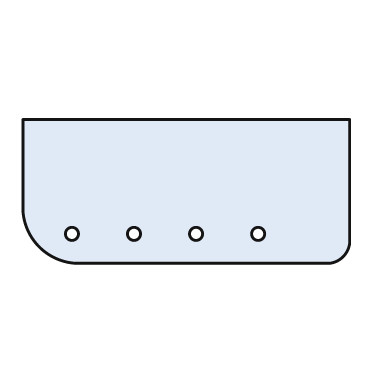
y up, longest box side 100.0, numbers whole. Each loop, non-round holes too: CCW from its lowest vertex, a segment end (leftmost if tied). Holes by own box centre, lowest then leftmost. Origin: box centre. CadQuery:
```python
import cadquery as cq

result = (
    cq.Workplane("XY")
    .moveTo(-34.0, -22.0)
    .lineTo(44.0, -22.0)
    .threePointArc((48.0, -20.0), (50.0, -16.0))
    .lineTo(50.0, 22.0)
    .lineTo(-50.0, 22.0)
    .lineTo(-50.0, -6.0)
    .threePointArc((-45.0, -17.0), (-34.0, -22.0))
    .close()
    .moveTo(-35.0, -13.0)
    .circle(2.0)
    .moveTo(-16.0, -13.0)
    .circle(2.0)
    .moveTo(3.0, -13.0)
    .circle(2.0)
    .moveTo(22.0, -13.0)
    .circle(2.0)
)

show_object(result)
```